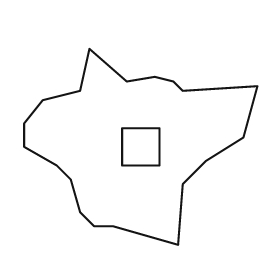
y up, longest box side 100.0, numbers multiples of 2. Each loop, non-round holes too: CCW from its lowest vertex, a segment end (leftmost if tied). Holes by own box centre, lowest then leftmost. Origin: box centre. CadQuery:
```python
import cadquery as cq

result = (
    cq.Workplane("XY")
    .moveTo(16.0, -42.0)
    .lineTo(18.0, -16.0)
    .lineTo(28.0, -6.0)
    .lineTo(44.0, 4.0)
    .lineTo(50.0, 26.0)
    .lineTo(18.0, 24.0)
    .lineTo(14.0, 28.0)
    .lineTo(6.0, 30.0)
    .lineTo(-6.0, 28.0)
    .lineTo(-22.0, 42.0)
    .lineTo(-26.0, 24.0)
    .lineTo(-42.0, 20.0)
    .lineTo(-50.0, 10.0)
    .lineTo(-50.0, 0.0)
    .lineTo(-36.0, -8.0)
    .lineTo(-30.0, -14.0)
    .lineTo(-26.0, -28.0)
    .lineTo(-20.0, -34.0)
    .lineTo(-12.0, -34.0)
    .close()
    .moveTo(-8.0, -8.0)
    .lineTo(8.0, -8.0)
    .lineTo(8.0, 8.0)
    .lineTo(-8.0, 8.0)
    .close()
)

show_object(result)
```